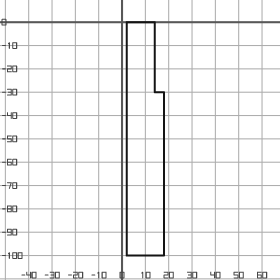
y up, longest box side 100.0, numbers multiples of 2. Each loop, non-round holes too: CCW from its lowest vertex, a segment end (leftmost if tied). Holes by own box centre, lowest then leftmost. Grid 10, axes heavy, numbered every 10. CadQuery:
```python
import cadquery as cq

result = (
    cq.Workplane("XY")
    .moveTo(2.0, -100.0)
    .lineTo(18.0, -100.0)
    .lineTo(18.0, -30.0)
    .lineTo(14.0, -30.0)
    .lineTo(14.0, 0.0)
    .lineTo(2.0, 0.0)
    .close()
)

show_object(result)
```